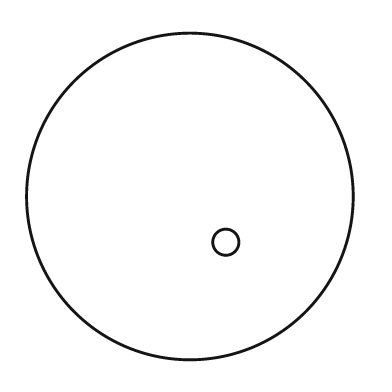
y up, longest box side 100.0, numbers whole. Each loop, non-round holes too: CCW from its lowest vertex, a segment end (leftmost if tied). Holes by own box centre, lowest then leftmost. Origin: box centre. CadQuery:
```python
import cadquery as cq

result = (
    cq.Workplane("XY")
    .moveTo(0.0, 0.0)
    .circle(50.0)
    .moveTo(11.0, -14.0)
    .circle(4.0)
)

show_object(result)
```